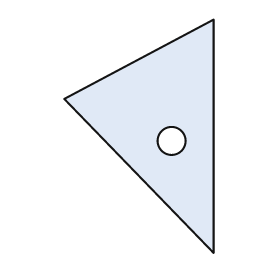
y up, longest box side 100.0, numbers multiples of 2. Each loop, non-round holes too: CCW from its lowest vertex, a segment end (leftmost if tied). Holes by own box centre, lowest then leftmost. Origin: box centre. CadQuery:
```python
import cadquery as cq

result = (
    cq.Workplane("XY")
    .moveTo(32.0, -50.0)
    .lineTo(32.0, 50.0)
    .lineTo(-32.0, 16.0)
    .close()
    .moveTo(14.0, -2.0)
    .circle(6.0)
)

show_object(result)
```